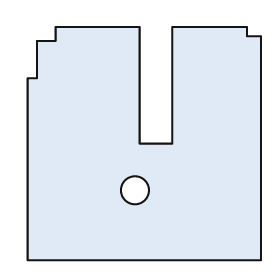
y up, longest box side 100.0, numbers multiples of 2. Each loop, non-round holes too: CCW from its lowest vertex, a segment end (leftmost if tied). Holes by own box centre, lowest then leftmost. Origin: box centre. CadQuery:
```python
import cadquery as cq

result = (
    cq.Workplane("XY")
    .moveTo(-50.0, -50.0)
    .lineTo(50.0, -50.0)
    .lineTo(50.0, 46.0)
    .lineTo(44.0, 46.0)
    .lineTo(44.0, 50.0)
    .lineTo(12.0, 50.0)
    .lineTo(12.0, 0.0)
    .lineTo(-2.0, 0.0)
    .lineTo(-2.0, 50.0)
    .lineTo(-38.0, 50.0)
    .lineTo(-38.0, 44.0)
    .lineTo(-46.0, 44.0)
    .lineTo(-46.0, 28.0)
    .lineTo(-50.0, 28.0)
    .close()
    .moveTo(-4.0, -20.0)
    .circle(6.0)
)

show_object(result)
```